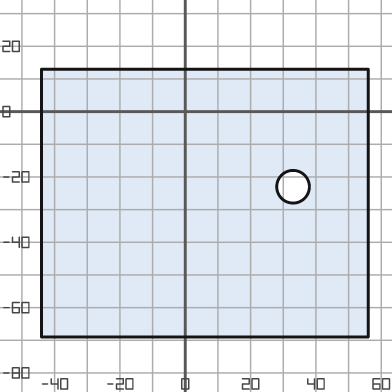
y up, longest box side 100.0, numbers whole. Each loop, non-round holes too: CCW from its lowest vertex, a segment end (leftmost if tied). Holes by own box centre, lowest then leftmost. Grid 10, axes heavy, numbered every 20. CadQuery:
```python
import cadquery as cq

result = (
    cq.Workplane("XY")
    .moveTo(-44.0, -69.0)
    .lineTo(56.0, -69.0)
    .lineTo(56.0, 13.0)
    .lineTo(-44.0, 13.0)
    .close()
    .moveTo(33.0, -23.0)
    .circle(5.0)
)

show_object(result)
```